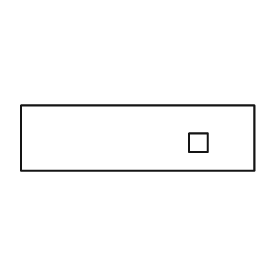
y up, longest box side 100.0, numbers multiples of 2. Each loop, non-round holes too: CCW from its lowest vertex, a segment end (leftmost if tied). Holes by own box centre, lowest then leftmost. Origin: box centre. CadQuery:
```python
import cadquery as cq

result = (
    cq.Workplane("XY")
    .moveTo(-50.0, -14.0)
    .lineTo(50.0, -14.0)
    .lineTo(50.0, 14.0)
    .lineTo(-50.0, 14.0)
    .close()
    .moveTo(22.0, -6.0)
    .lineTo(30.0, -6.0)
    .lineTo(30.0, 2.0)
    .lineTo(22.0, 2.0)
    .close()
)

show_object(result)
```